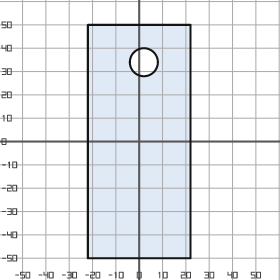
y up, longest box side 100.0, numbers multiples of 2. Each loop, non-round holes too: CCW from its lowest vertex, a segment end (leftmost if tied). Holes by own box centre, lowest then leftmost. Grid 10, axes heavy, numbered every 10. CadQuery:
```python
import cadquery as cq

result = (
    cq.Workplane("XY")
    .moveTo(-22.0, -50.0)
    .lineTo(22.0, -50.0)
    .lineTo(22.0, 50.0)
    .lineTo(-22.0, 50.0)
    .close()
    .moveTo(2.0, 34.0)
    .circle(6.0)
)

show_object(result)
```